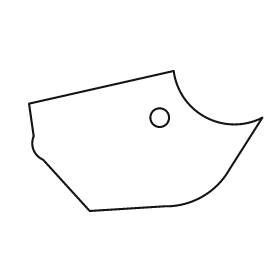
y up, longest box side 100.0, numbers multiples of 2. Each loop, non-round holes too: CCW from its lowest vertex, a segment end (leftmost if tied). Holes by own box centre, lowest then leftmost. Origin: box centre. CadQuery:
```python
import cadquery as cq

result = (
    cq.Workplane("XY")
    .moveTo(-24.0, -30.0)
    .lineTo(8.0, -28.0)
    .threePointArc((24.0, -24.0), (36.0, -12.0))
    .lineTo(50.0, 10.0)
    .threePointArc((26.0, 10.0), (12.0, 30.0))
    .lineTo(-50.0, 16.0)
    .lineTo(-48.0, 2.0)
    .threePointArc((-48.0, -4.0), (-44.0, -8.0))
    .close()
    .moveTo(6.0, 10.0)
    .circle(4.0)
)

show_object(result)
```